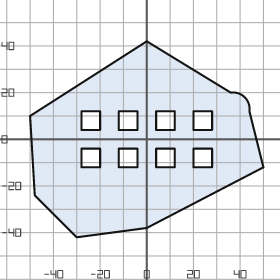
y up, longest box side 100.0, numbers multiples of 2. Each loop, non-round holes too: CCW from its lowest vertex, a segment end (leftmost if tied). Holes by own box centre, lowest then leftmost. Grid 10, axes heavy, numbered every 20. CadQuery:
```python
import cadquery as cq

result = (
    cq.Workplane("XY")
    .moveTo(-30.0, -42.0)
    .lineTo(0.0, -38.0)
    .lineTo(50.0, -12.0)
    .lineTo(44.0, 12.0)
    .threePointArc((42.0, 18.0), (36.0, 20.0))
    .lineTo(0.0, 42.0)
    .lineTo(-50.0, 10.0)
    .lineTo(-48.0, -24.0)
    .close()
    .moveTo(-28.0, -12.0)
    .lineTo(-20.0, -12.0)
    .lineTo(-20.0, -4.0)
    .lineTo(-28.0, -4.0)
    .close()
    .moveTo(-12.0, -12.0)
    .lineTo(-4.0, -12.0)
    .lineTo(-4.0, -4.0)
    .lineTo(-12.0, -4.0)
    .close()
    .moveTo(4.0, -12.0)
    .lineTo(12.0, -12.0)
    .lineTo(12.0, -4.0)
    .lineTo(4.0, -4.0)
    .close()
    .moveTo(20.0, -12.0)
    .lineTo(28.0, -12.0)
    .lineTo(28.0, -4.0)
    .lineTo(20.0, -4.0)
    .close()
    .moveTo(-28.0, 4.0)
    .lineTo(-20.0, 4.0)
    .lineTo(-20.0, 12.0)
    .lineTo(-28.0, 12.0)
    .close()
    .moveTo(-12.0, 4.0)
    .lineTo(-4.0, 4.0)
    .lineTo(-4.0, 12.0)
    .lineTo(-12.0, 12.0)
    .close()
    .moveTo(4.0, 4.0)
    .lineTo(12.0, 4.0)
    .lineTo(12.0, 12.0)
    .lineTo(4.0, 12.0)
    .close()
    .moveTo(20.0, 4.0)
    .lineTo(28.0, 4.0)
    .lineTo(28.0, 12.0)
    .lineTo(20.0, 12.0)
    .close()
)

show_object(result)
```